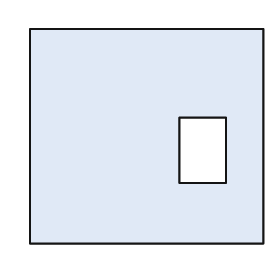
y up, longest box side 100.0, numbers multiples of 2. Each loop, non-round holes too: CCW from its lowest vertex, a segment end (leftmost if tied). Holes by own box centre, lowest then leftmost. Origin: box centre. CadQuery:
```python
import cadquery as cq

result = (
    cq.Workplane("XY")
    .moveTo(-50.0, -46.0)
    .lineTo(50.0, -46.0)
    .lineTo(50.0, 46.0)
    .lineTo(-50.0, 46.0)
    .close()
    .moveTo(14.0, -20.0)
    .lineTo(34.0, -20.0)
    .lineTo(34.0, 8.0)
    .lineTo(14.0, 8.0)
    .close()
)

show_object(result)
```